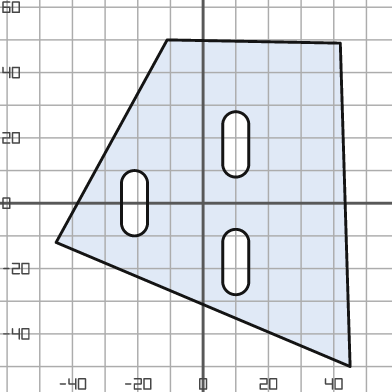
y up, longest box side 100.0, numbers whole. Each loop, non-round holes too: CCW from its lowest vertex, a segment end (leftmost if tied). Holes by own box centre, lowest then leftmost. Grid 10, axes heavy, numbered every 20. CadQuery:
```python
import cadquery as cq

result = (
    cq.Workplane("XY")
    .moveTo(45.0, -50.0)
    .lineTo(42.0, 49.0)
    .lineTo(-11.0, 50.0)
    .lineTo(-45.0, -12.0)
    .close()
    .moveTo(6.0, -24.0)
    .threePointArc((10.0, -28.0), (14.0, -24.0))
    .lineTo(14.0, -12.0)
    .threePointArc((10.0, -8.0), (6.0, -12.0))
    .close()
    .moveTo(-25.0, -6.0)
    .threePointArc((-21.0, -10.0), (-17.0, -6.0))
    .lineTo(-17.0, 6.0)
    .threePointArc((-21.0, 10.0), (-25.0, 6.0))
    .close()
    .moveTo(6.0, 12.0)
    .threePointArc((10.0, 8.0), (14.0, 12.0))
    .lineTo(14.0, 24.0)
    .threePointArc((10.0, 28.0), (6.0, 24.0))
    .close()
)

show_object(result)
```